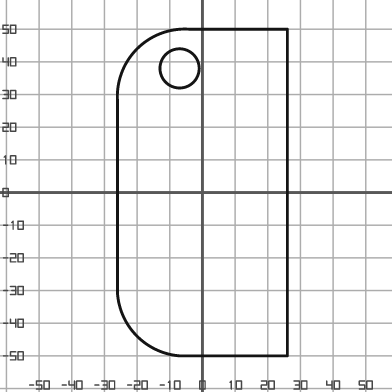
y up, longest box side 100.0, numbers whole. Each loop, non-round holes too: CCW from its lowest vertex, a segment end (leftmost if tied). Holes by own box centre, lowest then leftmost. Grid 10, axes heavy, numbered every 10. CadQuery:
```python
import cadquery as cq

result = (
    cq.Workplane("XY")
    .moveTo(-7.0, -50.0)
    .lineTo(26.0, -50.0)
    .lineTo(26.0, 50.0)
    .lineTo(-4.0, 50.0)
    .threePointArc((-20.0, 44.0), (-26.0, 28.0))
    .lineTo(-26.0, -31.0)
    .threePointArc((-20.0, -44.0), (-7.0, -50.0))
    .close()
    .moveTo(-7.0, 38.0)
    .circle(6.0)
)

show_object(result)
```